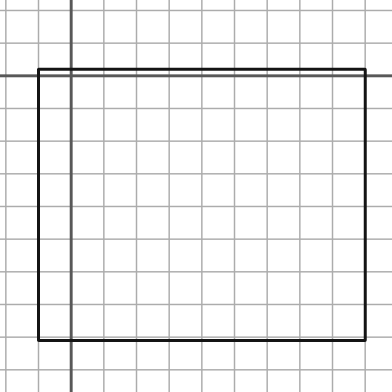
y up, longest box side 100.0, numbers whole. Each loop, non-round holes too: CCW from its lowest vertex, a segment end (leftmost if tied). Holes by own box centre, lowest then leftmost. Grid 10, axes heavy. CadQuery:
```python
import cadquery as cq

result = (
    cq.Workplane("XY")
    .moveTo(-10.0, -81.0)
    .lineTo(90.0, -81.0)
    .lineTo(90.0, 2.0)
    .lineTo(-10.0, 2.0)
    .close()
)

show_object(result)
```